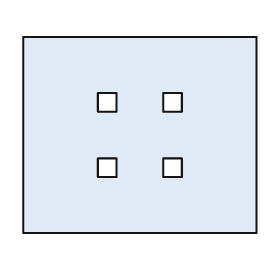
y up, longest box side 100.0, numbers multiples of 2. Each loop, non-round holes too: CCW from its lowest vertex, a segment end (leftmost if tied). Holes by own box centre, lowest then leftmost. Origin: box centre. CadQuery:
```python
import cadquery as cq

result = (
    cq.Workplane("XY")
    .moveTo(-50.0, -42.0)
    .lineTo(50.0, -42.0)
    .lineTo(50.0, 42.0)
    .lineTo(-50.0, 42.0)
    .close()
    .moveTo(-18.0, -18.0)
    .lineTo(-10.0, -18.0)
    .lineTo(-10.0, -10.0)
    .lineTo(-18.0, -10.0)
    .close()
    .moveTo(10.0, -18.0)
    .lineTo(18.0, -18.0)
    .lineTo(18.0, -10.0)
    .lineTo(10.0, -10.0)
    .close()
    .moveTo(-18.0, 10.0)
    .lineTo(-10.0, 10.0)
    .lineTo(-10.0, 18.0)
    .lineTo(-18.0, 18.0)
    .close()
    .moveTo(10.0, 10.0)
    .lineTo(18.0, 10.0)
    .lineTo(18.0, 18.0)
    .lineTo(10.0, 18.0)
    .close()
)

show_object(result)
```